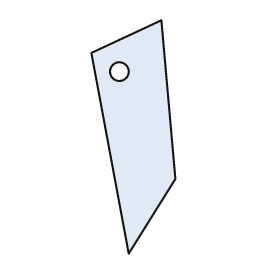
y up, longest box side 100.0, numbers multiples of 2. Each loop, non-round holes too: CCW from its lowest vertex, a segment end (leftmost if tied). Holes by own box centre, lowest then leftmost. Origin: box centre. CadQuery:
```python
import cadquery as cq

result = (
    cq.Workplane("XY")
    .moveTo(-2.0, -50.0)
    .lineTo(18.0, -18.0)
    .lineTo(12.0, 50.0)
    .lineTo(-18.0, 36.0)
    .close()
    .moveTo(-6.0, 28.0)
    .circle(4.0)
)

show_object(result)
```